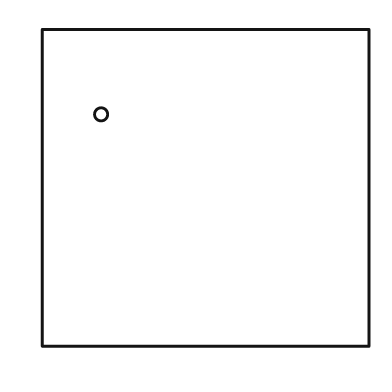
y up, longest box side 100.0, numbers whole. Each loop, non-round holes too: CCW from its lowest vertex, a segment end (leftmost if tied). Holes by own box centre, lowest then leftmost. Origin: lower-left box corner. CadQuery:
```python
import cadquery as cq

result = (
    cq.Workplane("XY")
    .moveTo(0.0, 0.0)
    .lineTo(100.0, 0.0)
    .lineTo(100.0, 97.0)
    .lineTo(0.0, 97.0)
    .close()
    .moveTo(18.0, 71.0)
    .circle(2.0)
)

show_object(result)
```